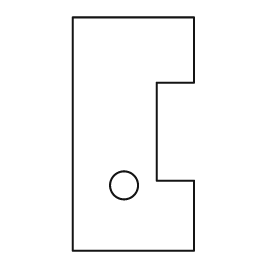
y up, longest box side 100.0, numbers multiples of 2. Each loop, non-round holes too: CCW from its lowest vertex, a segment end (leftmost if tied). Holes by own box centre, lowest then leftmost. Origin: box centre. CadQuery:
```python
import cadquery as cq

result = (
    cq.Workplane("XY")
    .moveTo(-26.0, -50.0)
    .lineTo(26.0, -50.0)
    .lineTo(26.0, -20.0)
    .lineTo(10.0, -20.0)
    .lineTo(10.0, 22.0)
    .lineTo(26.0, 22.0)
    .lineTo(26.0, 50.0)
    .lineTo(-26.0, 50.0)
    .close()
    .moveTo(-4.0, -22.0)
    .circle(6.0)
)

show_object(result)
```